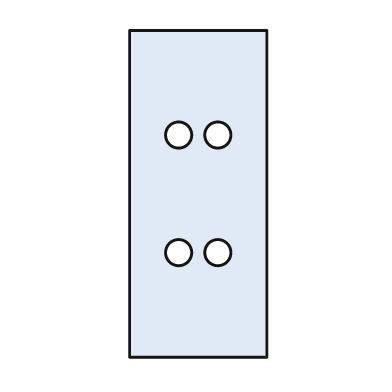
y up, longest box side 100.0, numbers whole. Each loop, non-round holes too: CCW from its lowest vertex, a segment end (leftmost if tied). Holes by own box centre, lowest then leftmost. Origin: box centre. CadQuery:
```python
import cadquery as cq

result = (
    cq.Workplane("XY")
    .moveTo(-21.0, -50.0)
    .lineTo(21.0, -50.0)
    .lineTo(21.0, 50.0)
    .lineTo(-21.0, 50.0)
    .close()
    .moveTo(-6.0, -18.0)
    .circle(4.0)
    .moveTo(6.0, -18.0)
    .circle(4.0)
    .moveTo(-6.0, 18.0)
    .circle(4.0)
    .moveTo(6.0, 18.0)
    .circle(4.0)
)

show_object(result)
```